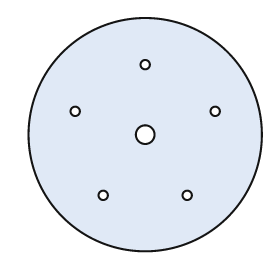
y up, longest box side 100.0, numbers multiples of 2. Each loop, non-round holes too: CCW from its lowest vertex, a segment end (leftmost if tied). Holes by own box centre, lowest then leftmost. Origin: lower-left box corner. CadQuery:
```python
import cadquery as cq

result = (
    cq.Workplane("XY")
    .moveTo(50.0, 50.0)
    .circle(50.0)
    .moveTo(32.0, 24.0)
    .circle(2.0)
    .moveTo(68.0, 24.0)
    .circle(2.0)
    .moveTo(50.0, 50.0)
    .circle(4.0)
    .moveTo(20.0, 60.0)
    .circle(2.0)
    .moveTo(80.0, 60.0)
    .circle(2.0)
    .moveTo(50.0, 80.0)
    .circle(2.0)
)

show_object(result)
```